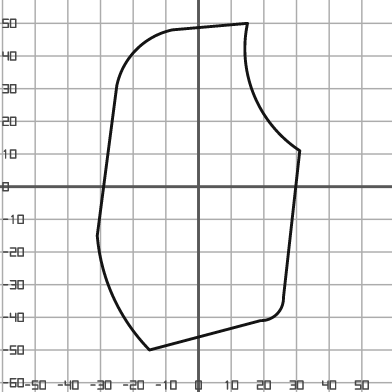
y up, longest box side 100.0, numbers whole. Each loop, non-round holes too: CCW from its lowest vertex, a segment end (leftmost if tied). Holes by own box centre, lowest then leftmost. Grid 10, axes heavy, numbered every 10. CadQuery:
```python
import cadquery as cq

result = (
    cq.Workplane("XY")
    .moveTo(-15.0, -50.0)
    .lineTo(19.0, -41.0)
    .threePointArc((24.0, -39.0), (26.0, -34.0))
    .lineTo(31.0, 11.0)
    .threePointArc((17.0, 28.0), (15.0, 50.0))
    .lineTo(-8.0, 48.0)
    .threePointArc((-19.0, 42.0), (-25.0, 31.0))
    .lineTo(-31.0, -15.0)
    .threePointArc((-26.0, -34.0), (-15.0, -50.0))
    .close()
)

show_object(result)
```